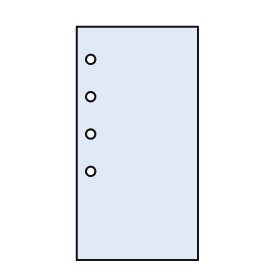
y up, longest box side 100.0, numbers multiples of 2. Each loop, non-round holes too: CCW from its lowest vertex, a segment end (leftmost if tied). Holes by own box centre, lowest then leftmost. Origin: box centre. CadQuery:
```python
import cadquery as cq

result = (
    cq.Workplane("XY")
    .moveTo(-26.0, -50.0)
    .lineTo(26.0, -50.0)
    .lineTo(26.0, 50.0)
    .lineTo(-26.0, 50.0)
    .close()
    .moveTo(-20.0, -12.0)
    .circle(2.0)
    .moveTo(-20.0, 4.0)
    .circle(2.0)
    .moveTo(-20.0, 20.0)
    .circle(2.0)
    .moveTo(-20.0, 36.0)
    .circle(2.0)
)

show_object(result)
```